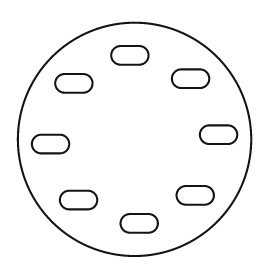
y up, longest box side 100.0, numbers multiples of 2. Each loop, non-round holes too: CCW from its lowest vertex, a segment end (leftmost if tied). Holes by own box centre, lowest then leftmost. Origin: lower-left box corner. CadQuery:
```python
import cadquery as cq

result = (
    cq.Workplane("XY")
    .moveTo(50.0, 50.0)
    .circle(50.0)
    .moveTo(48.0, 10.0)
    .lineTo(56.0, 10.0)
    .threePointArc((60.0, 14.0), (56.0, 18.0))
    .lineTo(48.0, 18.0)
    .threePointArc((44.0, 14.0), (48.0, 10.0))
    .close()
    .moveTo(22.0, 20.0)
    .lineTo(30.0, 20.0)
    .threePointArc((34.0, 24.0), (30.0, 28.0))
    .lineTo(22.0, 28.0)
    .threePointArc((18.0, 24.0), (22.0, 20.0))
    .close()
    .moveTo(72.0, 22.0)
    .lineTo(80.0, 22.0)
    .threePointArc((84.0, 26.0), (80.0, 30.0))
    .lineTo(72.0, 30.0)
    .threePointArc((68.0, 26.0), (72.0, 22.0))
    .close()
    .moveTo(10.0, 44.0)
    .lineTo(18.0, 44.0)
    .threePointArc((22.0, 48.0), (18.0, 52.0))
    .lineTo(10.0, 52.0)
    .threePointArc((6.0, 48.0), (10.0, 44.0))
    .close()
    .moveTo(82.0, 48.0)
    .lineTo(90.0, 48.0)
    .threePointArc((94.0, 52.0), (90.0, 56.0))
    .lineTo(82.0, 56.0)
    .threePointArc((78.0, 52.0), (82.0, 48.0))
    .close()
    .moveTo(20.0, 70.0)
    .lineTo(28.0, 70.0)
    .threePointArc((32.0, 74.0), (28.0, 78.0))
    .lineTo(20.0, 78.0)
    .threePointArc((16.0, 74.0), (20.0, 70.0))
    .close()
    .moveTo(70.0, 72.0)
    .lineTo(78.0, 72.0)
    .threePointArc((82.0, 76.0), (78.0, 80.0))
    .lineTo(70.0, 80.0)
    .threePointArc((66.0, 76.0), (70.0, 72.0))
    .close()
    .moveTo(44.0, 82.0)
    .lineTo(52.0, 82.0)
    .threePointArc((56.0, 86.0), (52.0, 90.0))
    .lineTo(44.0, 90.0)
    .threePointArc((40.0, 86.0), (44.0, 82.0))
    .close()
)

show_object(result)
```